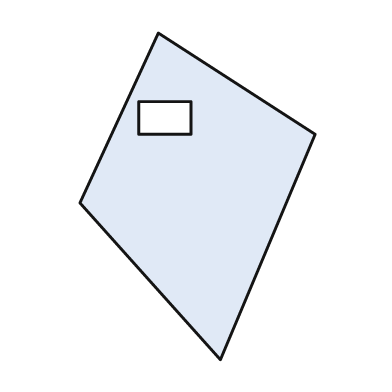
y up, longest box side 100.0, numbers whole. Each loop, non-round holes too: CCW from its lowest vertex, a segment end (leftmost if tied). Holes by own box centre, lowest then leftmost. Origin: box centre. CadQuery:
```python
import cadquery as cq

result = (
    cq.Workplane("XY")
    .moveTo(7.0, -50.0)
    .lineTo(36.0, 19.0)
    .lineTo(-12.0, 50.0)
    .lineTo(-36.0, -2.0)
    .close()
    .moveTo(-18.0, 19.0)
    .lineTo(-2.0, 19.0)
    .lineTo(-2.0, 29.0)
    .lineTo(-18.0, 29.0)
    .close()
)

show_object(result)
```